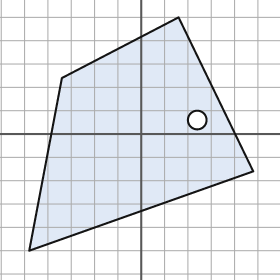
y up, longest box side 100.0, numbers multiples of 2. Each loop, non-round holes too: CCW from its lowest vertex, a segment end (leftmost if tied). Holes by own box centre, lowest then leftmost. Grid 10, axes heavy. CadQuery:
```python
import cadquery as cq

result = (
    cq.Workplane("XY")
    .moveTo(-48.0, -50.0)
    .lineTo(48.0, -16.0)
    .lineTo(16.0, 50.0)
    .lineTo(-34.0, 24.0)
    .close()
    .moveTo(24.0, 6.0)
    .circle(4.0)
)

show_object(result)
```